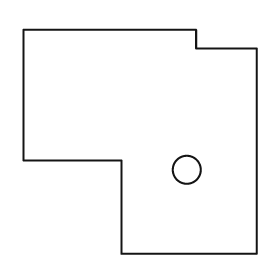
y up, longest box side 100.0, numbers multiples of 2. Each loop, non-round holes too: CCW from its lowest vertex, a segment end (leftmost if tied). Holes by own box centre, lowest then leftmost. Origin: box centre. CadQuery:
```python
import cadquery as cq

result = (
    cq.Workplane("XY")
    .moveTo(-8.0, -48.0)
    .lineTo(50.0, -48.0)
    .lineTo(50.0, 40.0)
    .lineTo(24.0, 40.0)
    .lineTo(24.0, 48.0)
    .lineTo(-50.0, 48.0)
    .lineTo(-50.0, -8.0)
    .lineTo(-8.0, -8.0)
    .close()
    .moveTo(20.0, -12.0)
    .circle(6.0)
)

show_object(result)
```